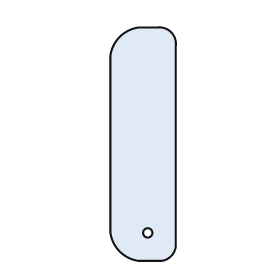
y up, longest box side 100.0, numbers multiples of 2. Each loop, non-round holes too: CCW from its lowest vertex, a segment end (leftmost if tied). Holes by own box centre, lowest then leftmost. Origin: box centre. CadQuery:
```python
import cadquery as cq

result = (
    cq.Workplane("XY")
    .moveTo(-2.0, -50.0)
    .lineTo(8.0, -50.0)
    .threePointArc((12.0, -48.0), (14.0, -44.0))
    .lineTo(14.0, 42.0)
    .threePointArc((12.0, 48.0), (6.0, 50.0))
    .lineTo(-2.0, 50.0)
    .threePointArc((-10.0, 46.0), (-14.0, 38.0))
    .lineTo(-14.0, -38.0)
    .threePointArc((-10.0, -46.0), (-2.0, -50.0))
    .close()
    .moveTo(2.0, -38.0)
    .circle(2.0)
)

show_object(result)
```